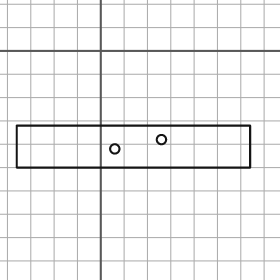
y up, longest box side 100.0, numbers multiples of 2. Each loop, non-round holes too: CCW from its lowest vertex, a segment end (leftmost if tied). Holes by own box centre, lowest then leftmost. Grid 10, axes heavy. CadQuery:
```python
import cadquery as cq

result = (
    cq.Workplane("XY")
    .moveTo(-36.0, -50.0)
    .lineTo(64.0, -50.0)
    .lineTo(64.0, -32.0)
    .lineTo(-36.0, -32.0)
    .close()
    .moveTo(6.0, -42.0)
    .circle(2.0)
    .moveTo(26.0, -38.0)
    .circle(2.0)
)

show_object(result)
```